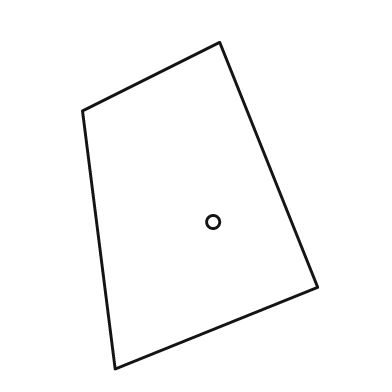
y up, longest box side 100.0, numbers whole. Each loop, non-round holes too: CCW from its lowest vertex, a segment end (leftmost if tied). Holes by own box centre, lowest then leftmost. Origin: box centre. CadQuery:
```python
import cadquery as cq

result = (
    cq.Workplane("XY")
    .moveTo(-26.0, -50.0)
    .lineTo(36.0, -25.0)
    .lineTo(6.0, 50.0)
    .lineTo(-36.0, 29.0)
    .close()
    .moveTo(4.0, -5.0)
    .circle(2.0)
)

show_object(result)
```